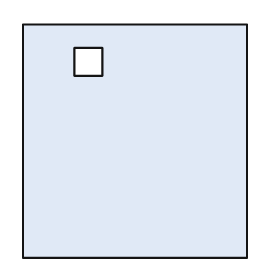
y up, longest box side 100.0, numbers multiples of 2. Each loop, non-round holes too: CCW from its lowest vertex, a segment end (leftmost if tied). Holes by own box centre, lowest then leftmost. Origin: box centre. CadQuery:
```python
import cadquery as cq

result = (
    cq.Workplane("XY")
    .moveTo(-48.0, -50.0)
    .lineTo(48.0, -50.0)
    .lineTo(48.0, 50.0)
    .lineTo(-48.0, 50.0)
    .close()
    .moveTo(-26.0, 28.0)
    .lineTo(-14.0, 28.0)
    .lineTo(-14.0, 40.0)
    .lineTo(-26.0, 40.0)
    .close()
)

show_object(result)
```